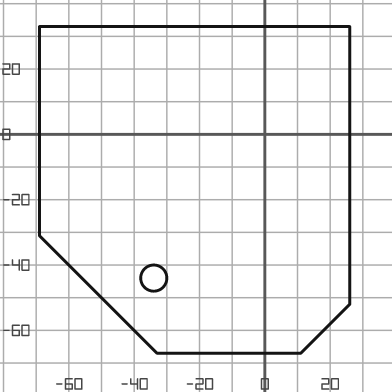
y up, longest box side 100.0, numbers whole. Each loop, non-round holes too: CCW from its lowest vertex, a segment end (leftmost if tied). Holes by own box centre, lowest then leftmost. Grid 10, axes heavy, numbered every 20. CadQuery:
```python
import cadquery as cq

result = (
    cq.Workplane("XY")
    .moveTo(-33.0, -67.0)
    .lineTo(11.0, -67.0)
    .lineTo(26.0, -52.0)
    .lineTo(26.0, 33.0)
    .lineTo(-69.0, 33.0)
    .lineTo(-69.0, -31.0)
    .close()
    .moveTo(-34.0, -44.0)
    .circle(4.0)
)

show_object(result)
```